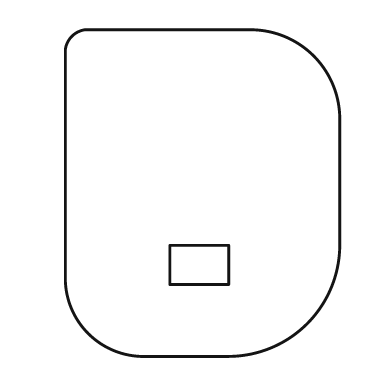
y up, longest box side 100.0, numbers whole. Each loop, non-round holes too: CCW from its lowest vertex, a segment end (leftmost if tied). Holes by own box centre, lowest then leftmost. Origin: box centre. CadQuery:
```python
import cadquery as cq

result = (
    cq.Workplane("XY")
    .moveTo(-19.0, -50.0)
    .lineTo(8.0, -50.0)
    .threePointArc((32.0, -40.0), (42.0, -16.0))
    .lineTo(42.0, 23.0)
    .threePointArc((34.0, 42.0), (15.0, 50.0))
    .lineTo(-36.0, 50.0)
    .threePointArc((-40.0, 48.0), (-42.0, 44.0))
    .lineTo(-42.0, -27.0)
    .threePointArc((-35.0, -43.0), (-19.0, -50.0))
    .close()
    .moveTo(-10.0, -28.0)
    .lineTo(8.0, -28.0)
    .lineTo(8.0, -16.0)
    .lineTo(-10.0, -16.0)
    .close()
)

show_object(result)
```